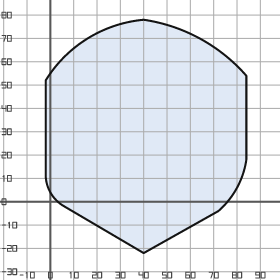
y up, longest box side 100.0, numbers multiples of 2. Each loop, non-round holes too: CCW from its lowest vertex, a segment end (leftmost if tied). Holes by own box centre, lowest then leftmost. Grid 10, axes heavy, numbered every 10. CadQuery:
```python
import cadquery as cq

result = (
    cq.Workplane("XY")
    .moveTo(40.0, -22.0)
    .lineTo(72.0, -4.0)
    .threePointArc((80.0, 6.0), (84.0, 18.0))
    .lineTo(84.0, 54.0)
    .threePointArc((64.0, 70.0), (40.0, 78.0))
    .threePointArc((16.0, 70.0), (-2.0, 52.0))
    .lineTo(-2.0, 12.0)
    .threePointArc((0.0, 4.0), (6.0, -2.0))
    .close()
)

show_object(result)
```